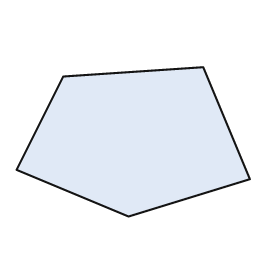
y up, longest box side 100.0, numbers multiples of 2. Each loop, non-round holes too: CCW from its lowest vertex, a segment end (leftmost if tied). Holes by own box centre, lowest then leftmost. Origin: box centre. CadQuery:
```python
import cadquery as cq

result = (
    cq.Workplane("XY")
    .moveTo(-2.0, -32.0)
    .lineTo(50.0, -16.0)
    .lineTo(30.0, 32.0)
    .lineTo(-30.0, 28.0)
    .lineTo(-50.0, -12.0)
    .close()
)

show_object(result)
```